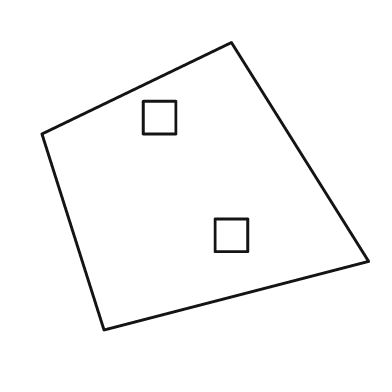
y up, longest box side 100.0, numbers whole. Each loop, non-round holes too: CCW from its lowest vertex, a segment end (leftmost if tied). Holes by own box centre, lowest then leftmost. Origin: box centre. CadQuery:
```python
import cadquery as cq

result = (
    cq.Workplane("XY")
    .moveTo(-31.0, -44.0)
    .lineTo(50.0, -23.0)
    .lineTo(8.0, 44.0)
    .lineTo(-50.0, 16.0)
    .close()
    .moveTo(3.0, -20.0)
    .lineTo(13.0, -20.0)
    .lineTo(13.0, -10.0)
    .lineTo(3.0, -10.0)
    .close()
    .moveTo(-19.0, 16.0)
    .lineTo(-9.0, 16.0)
    .lineTo(-9.0, 26.0)
    .lineTo(-19.0, 26.0)
    .close()
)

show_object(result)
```